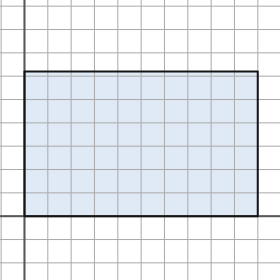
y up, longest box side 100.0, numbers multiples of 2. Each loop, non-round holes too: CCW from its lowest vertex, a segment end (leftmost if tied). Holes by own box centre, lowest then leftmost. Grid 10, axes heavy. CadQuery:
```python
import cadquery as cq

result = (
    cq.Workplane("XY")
    .moveTo(0.0, 0.0)
    .lineTo(100.0, 0.0)
    .lineTo(100.0, 62.0)
    .lineTo(0.0, 62.0)
    .close()
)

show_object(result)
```